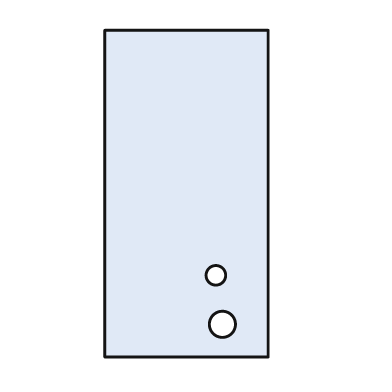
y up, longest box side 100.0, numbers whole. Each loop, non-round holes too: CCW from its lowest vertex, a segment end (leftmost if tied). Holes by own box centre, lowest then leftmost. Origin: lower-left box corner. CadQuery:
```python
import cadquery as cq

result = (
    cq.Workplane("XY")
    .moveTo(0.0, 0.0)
    .lineTo(50.0, 0.0)
    .lineTo(50.0, 100.0)
    .lineTo(0.0, 100.0)
    .close()
    .moveTo(36.0, 10.0)
    .circle(4.0)
    .moveTo(34.0, 25.0)
    .circle(3.0)
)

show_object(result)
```